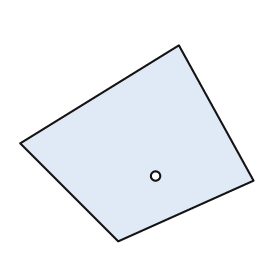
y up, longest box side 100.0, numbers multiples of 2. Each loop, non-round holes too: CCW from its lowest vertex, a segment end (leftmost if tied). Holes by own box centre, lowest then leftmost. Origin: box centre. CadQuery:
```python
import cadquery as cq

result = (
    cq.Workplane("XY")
    .moveTo(-8.0, -42.0)
    .lineTo(50.0, -16.0)
    .lineTo(18.0, 42.0)
    .lineTo(-50.0, 0.0)
    .close()
    .moveTo(8.0, -14.0)
    .circle(2.0)
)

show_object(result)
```